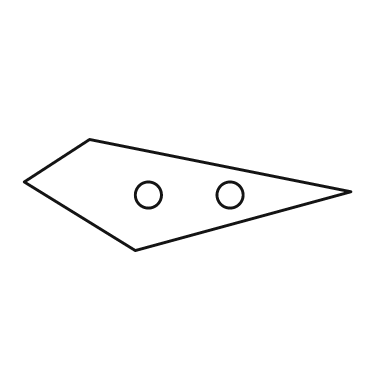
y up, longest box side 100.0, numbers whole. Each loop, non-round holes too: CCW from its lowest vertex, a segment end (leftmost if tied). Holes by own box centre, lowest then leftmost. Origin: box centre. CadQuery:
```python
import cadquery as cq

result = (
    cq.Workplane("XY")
    .moveTo(-16.0, -17.0)
    .lineTo(50.0, 1.0)
    .lineTo(-30.0, 17.0)
    .lineTo(-50.0, 4.0)
    .close()
    .moveTo(-12.0, 0.0)
    .circle(4.0)
    .moveTo(13.0, 0.0)
    .circle(4.0)
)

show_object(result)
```